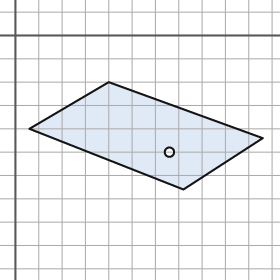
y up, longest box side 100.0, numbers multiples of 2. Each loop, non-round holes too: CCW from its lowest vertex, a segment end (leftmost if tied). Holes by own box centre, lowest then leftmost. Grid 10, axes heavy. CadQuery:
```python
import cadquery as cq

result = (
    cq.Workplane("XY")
    .moveTo(72.0, -66.0)
    .lineTo(106.0, -44.0)
    .lineTo(40.0, -20.0)
    .lineTo(6.0, -40.0)
    .close()
    .moveTo(66.0, -50.0)
    .circle(2.0)
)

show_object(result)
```